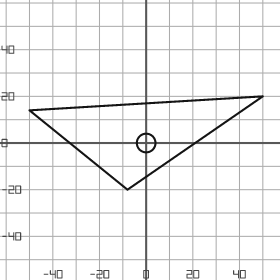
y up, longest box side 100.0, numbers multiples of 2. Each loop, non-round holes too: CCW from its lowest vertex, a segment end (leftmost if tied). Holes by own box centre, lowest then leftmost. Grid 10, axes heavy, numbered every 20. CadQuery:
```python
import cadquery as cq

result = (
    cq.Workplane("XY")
    .moveTo(-8.0, -20.0)
    .lineTo(50.0, 20.0)
    .lineTo(-50.0, 14.0)
    .close()
    .moveTo(0.0, 0.0)
    .circle(4.0)
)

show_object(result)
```